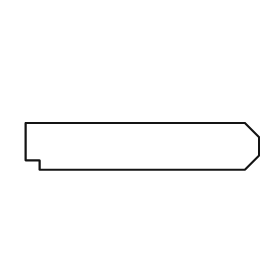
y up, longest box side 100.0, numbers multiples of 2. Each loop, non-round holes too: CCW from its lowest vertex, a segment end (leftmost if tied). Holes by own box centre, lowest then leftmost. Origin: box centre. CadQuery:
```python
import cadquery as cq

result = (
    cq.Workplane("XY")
    .moveTo(-44.0, -10.0)
    .lineTo(44.0, -10.0)
    .lineTo(50.0, -4.0)
    .lineTo(50.0, 4.0)
    .lineTo(44.0, 10.0)
    .lineTo(-50.0, 10.0)
    .lineTo(-50.0, -6.0)
    .lineTo(-44.0, -6.0)
    .close()
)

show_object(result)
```